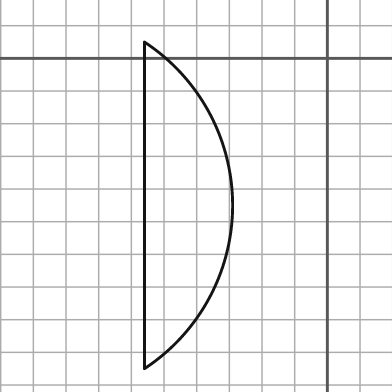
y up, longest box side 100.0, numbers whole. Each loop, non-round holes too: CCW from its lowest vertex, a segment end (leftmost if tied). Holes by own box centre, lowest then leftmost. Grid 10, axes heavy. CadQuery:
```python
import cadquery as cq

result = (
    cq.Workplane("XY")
    .moveTo(-56.0, -95.0)
    .threePointArc((-29.0, -45.0), (-56.0, 5.0))
    .close()
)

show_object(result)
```